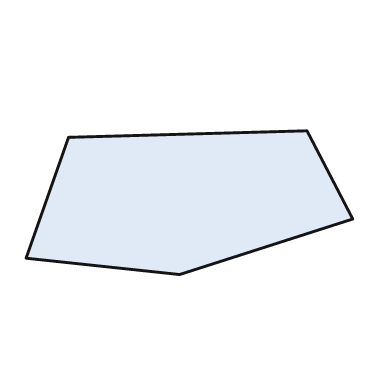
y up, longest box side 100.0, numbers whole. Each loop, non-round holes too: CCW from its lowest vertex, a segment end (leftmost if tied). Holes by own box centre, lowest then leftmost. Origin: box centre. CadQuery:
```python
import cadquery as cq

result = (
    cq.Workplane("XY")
    .moveTo(-3.0, -22.0)
    .lineTo(50.0, -5.0)
    .lineTo(36.0, 22.0)
    .lineTo(-37.0, 20.0)
    .lineTo(-50.0, -17.0)
    .close()
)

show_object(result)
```